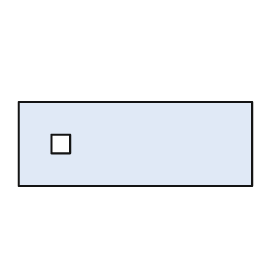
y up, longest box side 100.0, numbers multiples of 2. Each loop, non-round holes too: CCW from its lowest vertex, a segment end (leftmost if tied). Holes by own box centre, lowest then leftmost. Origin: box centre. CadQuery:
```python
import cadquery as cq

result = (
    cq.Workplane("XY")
    .moveTo(-50.0, -18.0)
    .lineTo(50.0, -18.0)
    .lineTo(50.0, 18.0)
    .lineTo(-50.0, 18.0)
    .close()
    .moveTo(-36.0, -4.0)
    .lineTo(-28.0, -4.0)
    .lineTo(-28.0, 4.0)
    .lineTo(-36.0, 4.0)
    .close()
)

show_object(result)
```